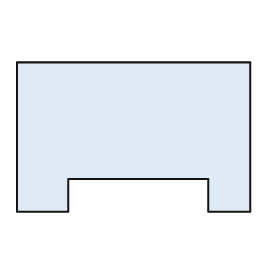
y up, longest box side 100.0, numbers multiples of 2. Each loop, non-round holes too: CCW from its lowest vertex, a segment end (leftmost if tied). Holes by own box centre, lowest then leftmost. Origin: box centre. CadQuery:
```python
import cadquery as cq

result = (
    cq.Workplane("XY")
    .moveTo(-50.0, -32.0)
    .lineTo(-28.0, -32.0)
    .lineTo(-28.0, -18.0)
    .lineTo(32.0, -18.0)
    .lineTo(32.0, -32.0)
    .lineTo(50.0, -32.0)
    .lineTo(50.0, 32.0)
    .lineTo(-50.0, 32.0)
    .close()
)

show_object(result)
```